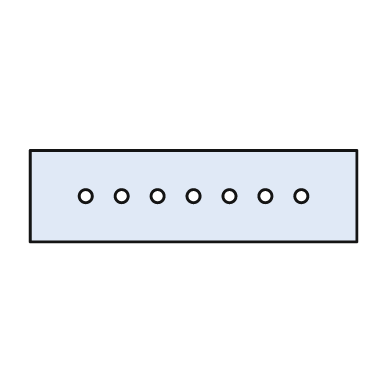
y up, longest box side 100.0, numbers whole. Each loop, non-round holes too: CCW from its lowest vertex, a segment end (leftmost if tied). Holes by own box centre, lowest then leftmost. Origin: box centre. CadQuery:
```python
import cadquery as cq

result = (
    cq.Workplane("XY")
    .moveTo(-50.0, -14.0)
    .lineTo(50.0, -14.0)
    .lineTo(50.0, 14.0)
    .lineTo(-50.0, 14.0)
    .close()
    .moveTo(-33.0, 0.0)
    .circle(2.0)
    .moveTo(-22.0, 0.0)
    .circle(2.0)
    .moveTo(-11.0, 0.0)
    .circle(2.0)
    .moveTo(0.0, 0.0)
    .circle(2.0)
    .moveTo(11.0, 0.0)
    .circle(2.0)
    .moveTo(22.0, 0.0)
    .circle(2.0)
    .moveTo(33.0, 0.0)
    .circle(2.0)
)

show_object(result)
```